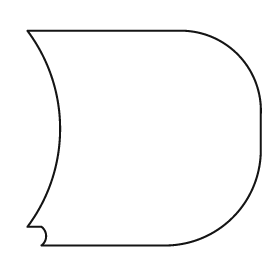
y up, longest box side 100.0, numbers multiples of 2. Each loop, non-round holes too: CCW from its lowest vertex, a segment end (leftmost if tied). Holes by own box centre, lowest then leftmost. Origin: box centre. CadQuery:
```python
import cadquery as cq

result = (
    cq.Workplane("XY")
    .moveTo(-44.0, -46.0)
    .lineTo(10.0, -46.0)
    .threePointArc((38.0, -34.0), (50.0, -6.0))
    .lineTo(50.0, 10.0)
    .threePointArc((40.0, 36.0), (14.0, 46.0))
    .lineTo(-50.0, 46.0)
    .threePointArc((-36.0, 4.0), (-50.0, -38.0))
    .lineTo(-44.0, -38.0)
    .threePointArc((-42.0, -42.0), (-44.0, -46.0))
    .close()
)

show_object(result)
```